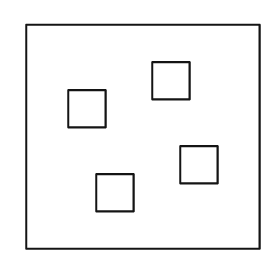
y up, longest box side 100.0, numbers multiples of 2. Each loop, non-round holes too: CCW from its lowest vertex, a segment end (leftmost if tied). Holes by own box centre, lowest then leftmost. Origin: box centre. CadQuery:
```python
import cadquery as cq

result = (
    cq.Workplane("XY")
    .moveTo(-50.0, -48.0)
    .lineTo(50.0, -48.0)
    .lineTo(50.0, 48.0)
    .lineTo(-50.0, 48.0)
    .close()
    .moveTo(-20.0, -32.0)
    .lineTo(-4.0, -32.0)
    .lineTo(-4.0, -16.0)
    .lineTo(-20.0, -16.0)
    .close()
    .moveTo(16.0, -20.0)
    .lineTo(32.0, -20.0)
    .lineTo(32.0, -4.0)
    .lineTo(16.0, -4.0)
    .close()
    .moveTo(-32.0, 4.0)
    .lineTo(-16.0, 4.0)
    .lineTo(-16.0, 20.0)
    .lineTo(-32.0, 20.0)
    .close()
    .moveTo(4.0, 16.0)
    .lineTo(20.0, 16.0)
    .lineTo(20.0, 32.0)
    .lineTo(4.0, 32.0)
    .close()
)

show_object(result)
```